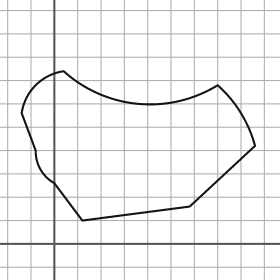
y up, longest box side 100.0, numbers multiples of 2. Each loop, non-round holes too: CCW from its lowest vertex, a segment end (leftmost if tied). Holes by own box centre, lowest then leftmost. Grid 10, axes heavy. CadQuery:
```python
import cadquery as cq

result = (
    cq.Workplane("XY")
    .moveTo(12.0, 10.0)
    .lineTo(58.0, 16.0)
    .lineTo(86.0, 42.0)
    .threePointArc((80.0, 56.0), (70.0, 68.0))
    .threePointArc((36.0, 60.0), (4.0, 74.0))
    .threePointArc((-8.0, 68.0), (-14.0, 56.0))
    .lineTo(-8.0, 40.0)
    .threePointArc((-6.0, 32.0), (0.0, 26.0))
    .close()
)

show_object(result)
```